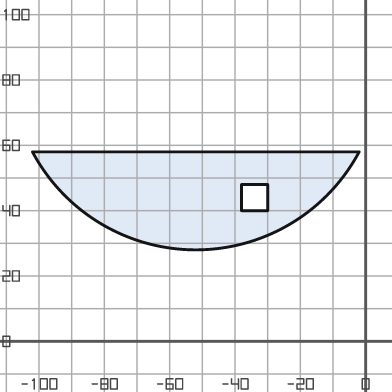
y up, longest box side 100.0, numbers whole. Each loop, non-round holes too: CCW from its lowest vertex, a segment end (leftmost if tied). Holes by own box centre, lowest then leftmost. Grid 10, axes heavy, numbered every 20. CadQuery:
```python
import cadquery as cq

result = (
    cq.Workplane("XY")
    .moveTo(-102.0, 58.0)
    .threePointArc((-52.0, 28.0), (-2.0, 58.0))
    .close()
    .moveTo(-38.0, 40.0)
    .lineTo(-30.0, 40.0)
    .lineTo(-30.0, 48.0)
    .lineTo(-38.0, 48.0)
    .close()
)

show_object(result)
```